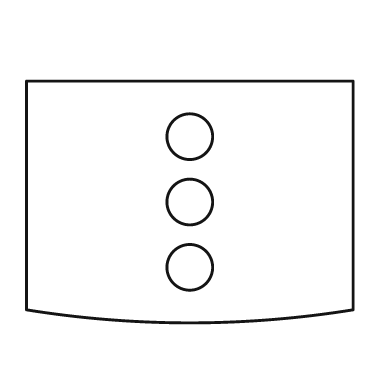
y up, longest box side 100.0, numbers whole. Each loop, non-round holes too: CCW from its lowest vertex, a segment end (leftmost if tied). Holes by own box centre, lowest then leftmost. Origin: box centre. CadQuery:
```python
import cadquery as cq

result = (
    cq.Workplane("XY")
    .moveTo(-50.0, -33.0)
    .threePointArc((0.0, -37.0), (50.0, -33.0))
    .lineTo(50.0, 37.0)
    .lineTo(-50.0, 37.0)
    .close()
    .moveTo(0.0, -20.0)
    .circle(7.0)
    .moveTo(0.0, 0.0)
    .circle(7.0)
    .moveTo(0.0, 20.0)
    .circle(7.0)
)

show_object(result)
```